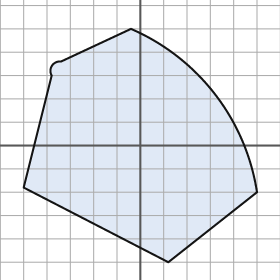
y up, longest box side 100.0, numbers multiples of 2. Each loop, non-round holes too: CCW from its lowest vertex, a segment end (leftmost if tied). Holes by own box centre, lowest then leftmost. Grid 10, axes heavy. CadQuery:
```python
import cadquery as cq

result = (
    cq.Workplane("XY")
    .moveTo(12.0, -50.0)
    .lineTo(50.0, -20.0)
    .threePointArc((32.0, 22.0), (-4.0, 50.0))
    .lineTo(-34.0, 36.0)
    .threePointArc((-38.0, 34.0), (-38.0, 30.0))
    .lineTo(-50.0, -18.0)
    .close()
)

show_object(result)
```